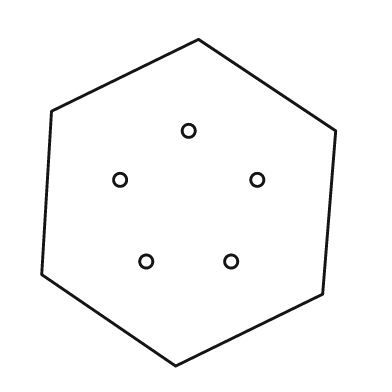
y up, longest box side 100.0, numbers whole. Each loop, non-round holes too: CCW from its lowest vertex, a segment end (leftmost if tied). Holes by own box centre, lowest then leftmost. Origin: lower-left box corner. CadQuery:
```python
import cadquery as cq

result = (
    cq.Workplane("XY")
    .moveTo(41.0, 0.0)
    .lineTo(86.0, 22.0)
    .lineTo(90.0, 72.0)
    .lineTo(48.0, 100.0)
    .lineTo(3.0, 78.0)
    .lineTo(0.0, 28.0)
    .close()
    .moveTo(32.0, 32.0)
    .circle(2.0)
    .moveTo(58.0, 32.0)
    .circle(2.0)
    .moveTo(24.0, 57.0)
    .circle(2.0)
    .moveTo(66.0, 57.0)
    .circle(2.0)
    .moveTo(45.0, 72.0)
    .circle(2.0)
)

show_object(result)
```